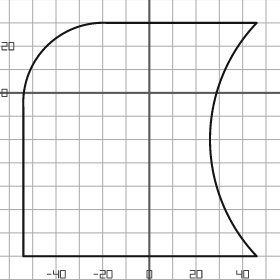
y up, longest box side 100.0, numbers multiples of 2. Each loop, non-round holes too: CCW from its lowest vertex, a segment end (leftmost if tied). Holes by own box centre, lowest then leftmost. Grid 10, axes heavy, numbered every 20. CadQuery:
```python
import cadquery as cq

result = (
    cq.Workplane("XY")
    .moveTo(-54.0, -70.0)
    .lineTo(46.0, -70.0)
    .threePointArc((26.0, -20.0), (46.0, 30.0))
    .lineTo(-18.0, 30.0)
    .threePointArc((-44.0, 20.0), (-54.0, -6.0))
    .close()
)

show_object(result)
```